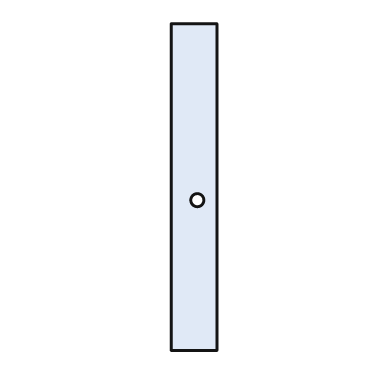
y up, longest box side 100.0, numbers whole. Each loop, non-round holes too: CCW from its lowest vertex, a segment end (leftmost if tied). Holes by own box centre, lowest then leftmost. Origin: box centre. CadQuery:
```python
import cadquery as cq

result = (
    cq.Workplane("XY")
    .moveTo(-7.0, -50.0)
    .lineTo(7.0, -50.0)
    .lineTo(7.0, 50.0)
    .lineTo(-7.0, 50.0)
    .close()
    .moveTo(1.0, -4.0)
    .circle(2.0)
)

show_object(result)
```